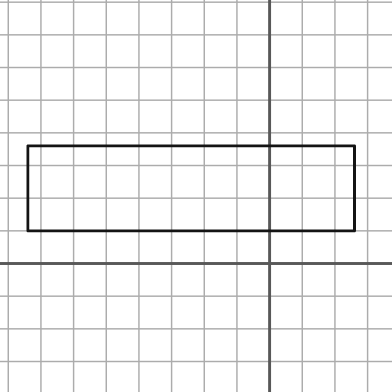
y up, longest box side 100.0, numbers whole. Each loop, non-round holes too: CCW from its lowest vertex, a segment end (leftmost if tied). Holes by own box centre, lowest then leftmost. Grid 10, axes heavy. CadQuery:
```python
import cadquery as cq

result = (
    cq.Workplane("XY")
    .moveTo(-74.0, 10.0)
    .lineTo(26.0, 10.0)
    .lineTo(26.0, 36.0)
    .lineTo(-74.0, 36.0)
    .close()
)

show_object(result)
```